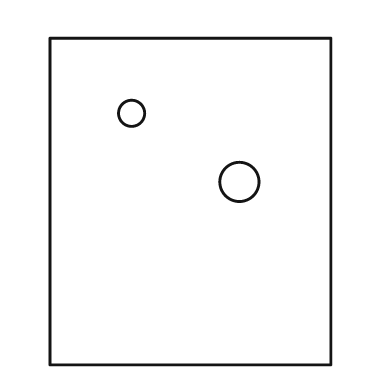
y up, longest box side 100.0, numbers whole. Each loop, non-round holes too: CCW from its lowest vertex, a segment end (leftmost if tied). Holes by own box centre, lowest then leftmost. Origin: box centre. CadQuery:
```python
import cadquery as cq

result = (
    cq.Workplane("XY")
    .moveTo(-43.0, -50.0)
    .lineTo(43.0, -50.0)
    .lineTo(43.0, 50.0)
    .lineTo(-43.0, 50.0)
    .close()
    .moveTo(15.0, 6.0)
    .circle(6.0)
    .moveTo(-18.0, 27.0)
    .circle(4.0)
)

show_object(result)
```